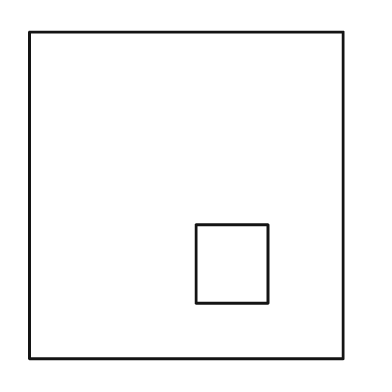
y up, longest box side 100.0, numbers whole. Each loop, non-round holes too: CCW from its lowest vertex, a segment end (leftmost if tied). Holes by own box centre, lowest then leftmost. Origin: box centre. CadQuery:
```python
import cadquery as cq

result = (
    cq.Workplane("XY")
    .moveTo(-48.0, -50.0)
    .lineTo(48.0, -50.0)
    .lineTo(48.0, 50.0)
    .lineTo(-48.0, 50.0)
    .close()
    .moveTo(3.0, -33.0)
    .lineTo(25.0, -33.0)
    .lineTo(25.0, -9.0)
    .lineTo(3.0, -9.0)
    .close()
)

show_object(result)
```